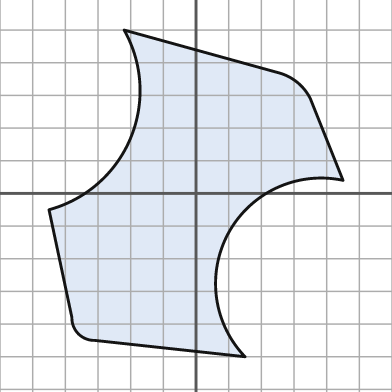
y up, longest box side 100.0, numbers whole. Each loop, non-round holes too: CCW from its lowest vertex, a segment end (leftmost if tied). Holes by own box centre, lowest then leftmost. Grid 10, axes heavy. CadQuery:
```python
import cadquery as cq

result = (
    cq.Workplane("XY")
    .moveTo(15.0, -50.0)
    .threePointArc((10.0, -12.0), (45.0, 4.0))
    .lineTo(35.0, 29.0)
    .threePointArc((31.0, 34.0), (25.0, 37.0))
    .lineTo(-22.0, 50.0)
    .threePointArc((-20.0, 17.0), (-45.0, -5.0))
    .lineTo(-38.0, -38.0)
    .threePointArc((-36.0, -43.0), (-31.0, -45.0))
    .close()
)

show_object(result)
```